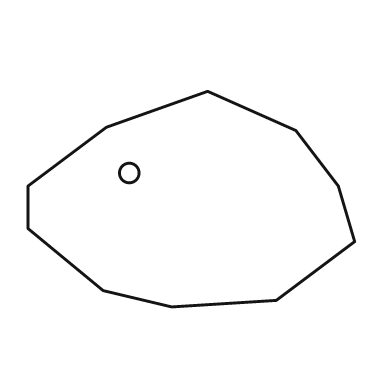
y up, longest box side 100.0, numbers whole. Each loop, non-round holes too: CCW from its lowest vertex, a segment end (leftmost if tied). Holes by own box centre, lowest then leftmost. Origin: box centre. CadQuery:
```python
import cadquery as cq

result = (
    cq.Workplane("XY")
    .moveTo(-6.0, -33.0)
    .lineTo(26.0, -31.0)
    .lineTo(50.0, -13.0)
    .lineTo(45.0, 4.0)
    .lineTo(32.0, 21.0)
    .lineTo(5.0, 33.0)
    .lineTo(-26.0, 22.0)
    .lineTo(-50.0, 4.0)
    .lineTo(-50.0, -9.0)
    .lineTo(-27.0, -28.0)
    .close()
    .moveTo(-19.0, 8.0)
    .circle(3.0)
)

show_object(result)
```